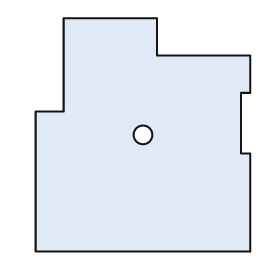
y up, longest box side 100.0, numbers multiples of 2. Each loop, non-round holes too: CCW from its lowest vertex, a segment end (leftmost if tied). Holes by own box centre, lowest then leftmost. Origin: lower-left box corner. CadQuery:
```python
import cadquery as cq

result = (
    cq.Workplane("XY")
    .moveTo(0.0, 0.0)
    .lineTo(92.0, 0.0)
    .lineTo(92.0, 42.0)
    .lineTo(88.0, 42.0)
    .lineTo(88.0, 68.0)
    .lineTo(92.0, 68.0)
    .lineTo(92.0, 84.0)
    .lineTo(52.0, 84.0)
    .lineTo(52.0, 100.0)
    .lineTo(12.0, 100.0)
    .lineTo(12.0, 60.0)
    .lineTo(0.0, 60.0)
    .close()
    .moveTo(46.0, 50.0)
    .circle(4.0)
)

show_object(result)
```